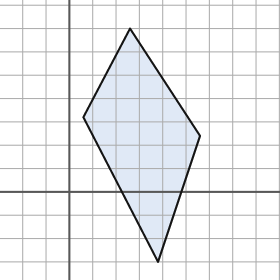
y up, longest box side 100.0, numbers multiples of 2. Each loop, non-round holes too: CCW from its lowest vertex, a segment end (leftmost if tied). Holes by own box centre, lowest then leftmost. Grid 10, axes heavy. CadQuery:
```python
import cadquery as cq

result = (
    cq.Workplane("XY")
    .moveTo(38.0, -30.0)
    .lineTo(56.0, 24.0)
    .lineTo(26.0, 70.0)
    .lineTo(6.0, 32.0)
    .close()
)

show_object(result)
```